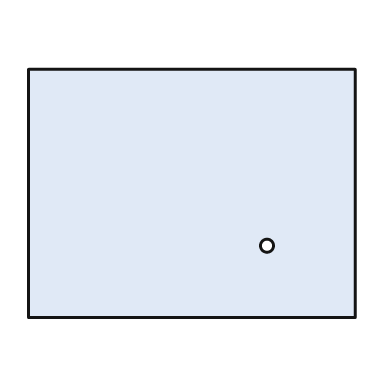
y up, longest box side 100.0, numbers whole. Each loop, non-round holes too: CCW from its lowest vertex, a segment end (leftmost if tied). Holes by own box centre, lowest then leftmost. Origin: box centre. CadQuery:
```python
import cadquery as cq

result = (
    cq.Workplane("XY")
    .moveTo(-50.0, -38.0)
    .lineTo(50.0, -38.0)
    .lineTo(50.0, 38.0)
    .lineTo(-50.0, 38.0)
    .close()
    .moveTo(23.0, -16.0)
    .circle(2.0)
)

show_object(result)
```